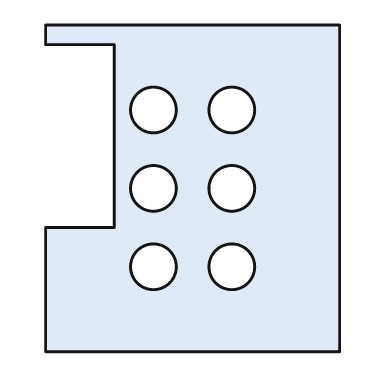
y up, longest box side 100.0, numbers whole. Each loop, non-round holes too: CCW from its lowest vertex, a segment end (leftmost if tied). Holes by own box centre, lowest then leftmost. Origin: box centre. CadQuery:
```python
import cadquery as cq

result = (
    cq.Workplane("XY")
    .moveTo(-45.0, -50.0)
    .lineTo(45.0, -50.0)
    .lineTo(45.0, 50.0)
    .lineTo(-45.0, 50.0)
    .lineTo(-45.0, 44.0)
    .lineTo(-24.0, 44.0)
    .lineTo(-24.0, -12.0)
    .lineTo(-45.0, -12.0)
    .close()
    .moveTo(-12.0, -24.0)
    .circle(7.0)
    .moveTo(12.0, -24.0)
    .circle(7.0)
    .moveTo(-12.0, 0.0)
    .circle(7.0)
    .moveTo(12.0, 0.0)
    .circle(7.0)
    .moveTo(-12.0, 24.0)
    .circle(7.0)
    .moveTo(12.0, 24.0)
    .circle(7.0)
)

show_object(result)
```